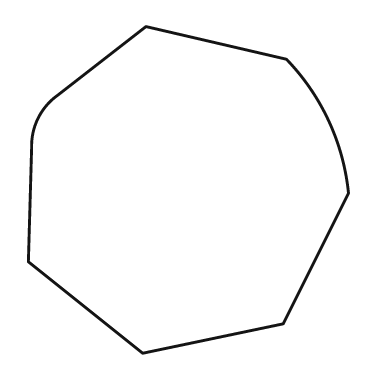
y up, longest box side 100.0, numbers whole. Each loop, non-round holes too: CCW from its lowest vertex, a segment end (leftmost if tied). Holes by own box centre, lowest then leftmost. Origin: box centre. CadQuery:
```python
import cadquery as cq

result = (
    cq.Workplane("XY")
    .moveTo(-14.0, -50.0)
    .lineTo(29.0, -41.0)
    .lineTo(49.0, -1.0)
    .threePointArc((43.0, 21.0), (30.0, 40.0))
    .lineTo(-13.0, 50.0)
    .lineTo(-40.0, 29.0)
    .threePointArc((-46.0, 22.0), (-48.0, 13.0))
    .lineTo(-49.0, -22.0)
    .close()
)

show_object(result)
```